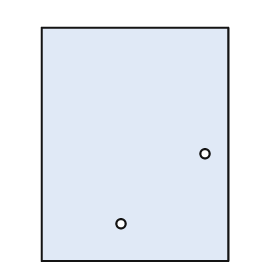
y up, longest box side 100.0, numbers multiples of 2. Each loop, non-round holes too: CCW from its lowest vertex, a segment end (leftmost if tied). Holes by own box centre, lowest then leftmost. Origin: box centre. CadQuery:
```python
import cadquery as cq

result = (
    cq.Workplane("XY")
    .moveTo(-40.0, -50.0)
    .lineTo(40.0, -50.0)
    .lineTo(40.0, 50.0)
    .lineTo(-40.0, 50.0)
    .close()
    .moveTo(-6.0, -34.0)
    .circle(2.0)
    .moveTo(30.0, -4.0)
    .circle(2.0)
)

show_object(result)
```